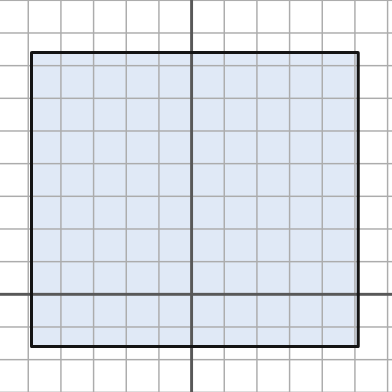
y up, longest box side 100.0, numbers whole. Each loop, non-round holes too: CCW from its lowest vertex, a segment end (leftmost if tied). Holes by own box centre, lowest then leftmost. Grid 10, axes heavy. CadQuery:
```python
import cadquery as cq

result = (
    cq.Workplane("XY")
    .moveTo(-49.0, -16.0)
    .lineTo(51.0, -16.0)
    .lineTo(51.0, 74.0)
    .lineTo(-49.0, 74.0)
    .close()
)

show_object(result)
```